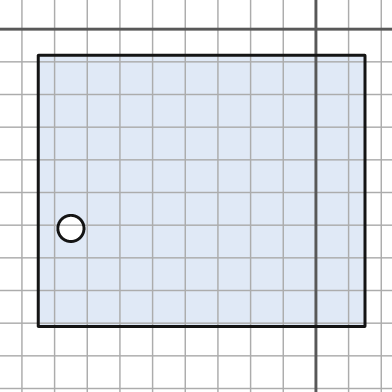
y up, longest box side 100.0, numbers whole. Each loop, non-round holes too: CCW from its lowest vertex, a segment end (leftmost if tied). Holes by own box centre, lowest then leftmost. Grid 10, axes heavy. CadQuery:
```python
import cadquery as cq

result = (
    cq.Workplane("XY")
    .moveTo(-85.0, -91.0)
    .lineTo(15.0, -91.0)
    .lineTo(15.0, -8.0)
    .lineTo(-85.0, -8.0)
    .close()
    .moveTo(-75.0, -61.0)
    .circle(4.0)
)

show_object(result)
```